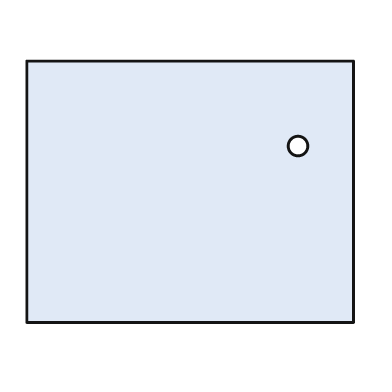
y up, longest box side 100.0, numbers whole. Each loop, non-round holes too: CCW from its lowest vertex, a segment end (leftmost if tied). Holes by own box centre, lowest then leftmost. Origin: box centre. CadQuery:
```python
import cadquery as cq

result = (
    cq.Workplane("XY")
    .moveTo(-50.0, -40.0)
    .lineTo(50.0, -40.0)
    .lineTo(50.0, 40.0)
    .lineTo(-50.0, 40.0)
    .close()
    .moveTo(33.0, 14.0)
    .circle(3.0)
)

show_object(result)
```